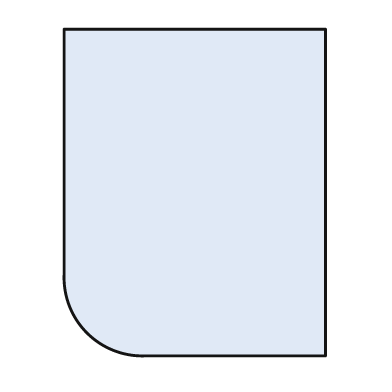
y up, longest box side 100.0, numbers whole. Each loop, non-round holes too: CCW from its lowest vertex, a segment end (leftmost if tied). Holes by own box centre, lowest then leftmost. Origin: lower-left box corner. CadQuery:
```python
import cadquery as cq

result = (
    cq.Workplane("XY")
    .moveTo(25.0, 0.0)
    .lineTo(80.0, 0.0)
    .lineTo(80.0, 100.0)
    .lineTo(0.0, 100.0)
    .lineTo(0.0, 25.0)
    .threePointArc((7.0, 7.0), (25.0, 0.0))
    .close()
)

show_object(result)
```